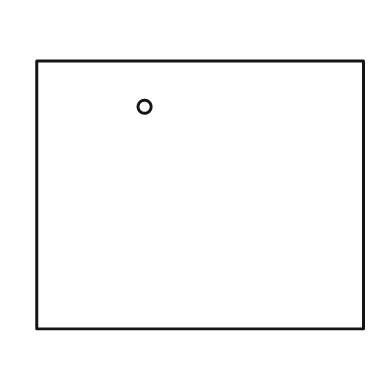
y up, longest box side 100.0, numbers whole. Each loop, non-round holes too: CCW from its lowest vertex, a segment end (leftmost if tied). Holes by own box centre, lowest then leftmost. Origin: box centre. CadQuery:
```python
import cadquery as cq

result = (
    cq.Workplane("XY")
    .moveTo(-50.0, -41.0)
    .lineTo(50.0, -41.0)
    .lineTo(50.0, 41.0)
    .lineTo(-50.0, 41.0)
    .close()
    .moveTo(-17.0, 27.0)
    .circle(2.0)
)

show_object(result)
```